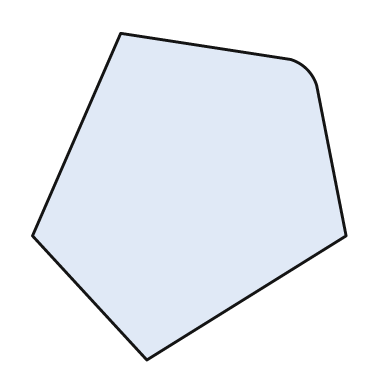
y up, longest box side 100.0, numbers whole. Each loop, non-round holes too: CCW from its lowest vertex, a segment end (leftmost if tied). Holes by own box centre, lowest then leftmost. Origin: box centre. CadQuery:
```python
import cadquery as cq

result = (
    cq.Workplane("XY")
    .moveTo(-13.0, -50.0)
    .lineTo(48.0, -12.0)
    .lineTo(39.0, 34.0)
    .threePointArc((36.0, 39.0), (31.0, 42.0))
    .lineTo(-21.0, 50.0)
    .lineTo(-48.0, -12.0)
    .close()
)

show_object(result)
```